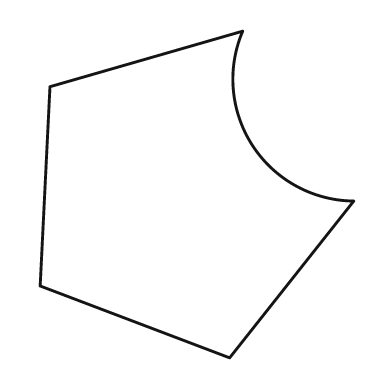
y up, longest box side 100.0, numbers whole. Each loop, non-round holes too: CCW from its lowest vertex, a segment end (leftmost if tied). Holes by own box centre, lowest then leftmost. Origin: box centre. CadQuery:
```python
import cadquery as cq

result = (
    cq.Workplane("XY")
    .moveTo(10.0, -50.0)
    .lineTo(48.0, -2.0)
    .threePointArc((17.0, 15.0), (14.0, 50.0))
    .lineTo(-45.0, 33.0)
    .lineTo(-48.0, -28.0)
    .close()
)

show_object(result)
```